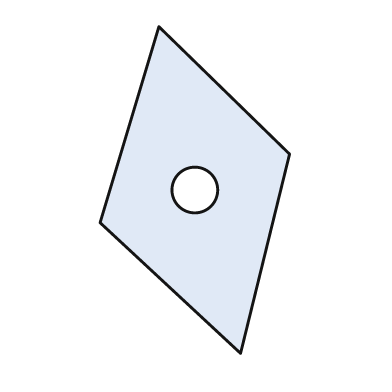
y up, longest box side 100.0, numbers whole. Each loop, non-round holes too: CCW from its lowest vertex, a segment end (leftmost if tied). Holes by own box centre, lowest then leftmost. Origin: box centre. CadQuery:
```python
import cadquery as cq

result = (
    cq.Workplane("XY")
    .moveTo(14.0, -50.0)
    .lineTo(29.0, 11.0)
    .lineTo(-11.0, 50.0)
    .lineTo(-29.0, -10.0)
    .close()
    .moveTo(0.0, 0.0)
    .circle(7.0)
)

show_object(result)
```